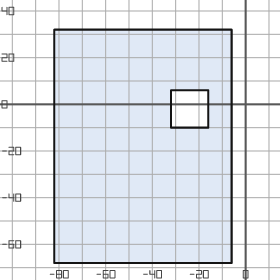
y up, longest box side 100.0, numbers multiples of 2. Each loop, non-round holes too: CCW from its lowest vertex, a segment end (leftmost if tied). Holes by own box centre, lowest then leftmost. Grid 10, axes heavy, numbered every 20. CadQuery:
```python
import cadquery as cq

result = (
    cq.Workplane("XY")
    .moveTo(-82.0, -68.0)
    .lineTo(-6.0, -68.0)
    .lineTo(-6.0, 32.0)
    .lineTo(-82.0, 32.0)
    .close()
    .moveTo(-32.0, -10.0)
    .lineTo(-16.0, -10.0)
    .lineTo(-16.0, 6.0)
    .lineTo(-32.0, 6.0)
    .close()
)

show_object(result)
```